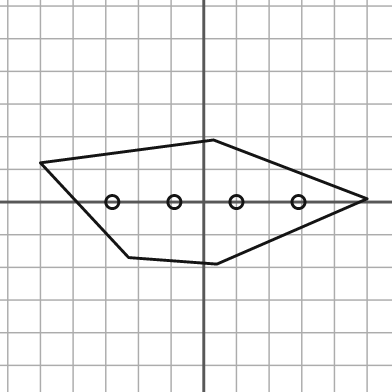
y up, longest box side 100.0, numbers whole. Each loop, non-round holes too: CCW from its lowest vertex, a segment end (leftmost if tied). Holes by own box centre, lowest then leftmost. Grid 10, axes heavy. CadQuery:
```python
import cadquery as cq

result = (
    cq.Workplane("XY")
    .moveTo(4.0, -19.0)
    .lineTo(50.0, 1.0)
    .lineTo(3.0, 19.0)
    .lineTo(-50.0, 12.0)
    .lineTo(-23.0, -17.0)
    .close()
    .moveTo(-28.0, 0.0)
    .circle(2.0)
    .moveTo(-9.0, 0.0)
    .circle(2.0)
    .moveTo(10.0, 0.0)
    .circle(2.0)
    .moveTo(29.0, 0.0)
    .circle(2.0)
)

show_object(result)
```